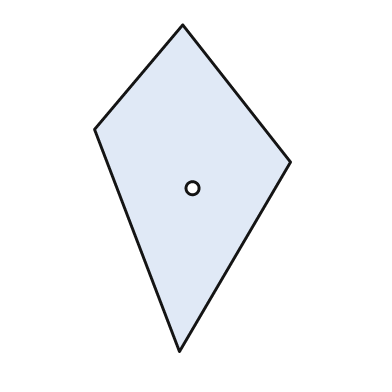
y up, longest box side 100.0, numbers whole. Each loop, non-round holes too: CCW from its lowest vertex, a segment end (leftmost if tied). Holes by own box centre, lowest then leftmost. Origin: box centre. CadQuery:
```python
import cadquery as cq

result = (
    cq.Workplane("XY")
    .moveTo(-4.0, -50.0)
    .lineTo(30.0, 8.0)
    .lineTo(-3.0, 50.0)
    .lineTo(-30.0, 18.0)
    .close()
    .moveTo(0.0, 0.0)
    .circle(2.0)
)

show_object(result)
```